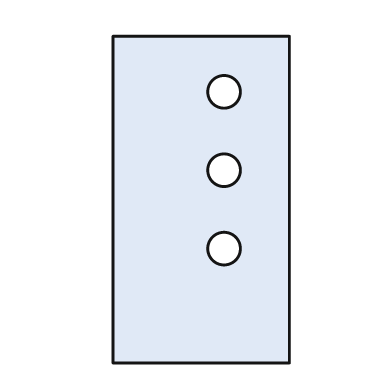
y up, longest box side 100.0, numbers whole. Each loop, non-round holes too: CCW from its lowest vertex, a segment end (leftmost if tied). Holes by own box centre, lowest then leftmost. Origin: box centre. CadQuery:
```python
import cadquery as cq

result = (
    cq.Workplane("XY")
    .moveTo(-27.0, -50.0)
    .lineTo(27.0, -50.0)
    .lineTo(27.0, 50.0)
    .lineTo(-27.0, 50.0)
    .close()
    .moveTo(7.0, -15.0)
    .circle(5.0)
    .moveTo(7.0, 9.0)
    .circle(5.0)
    .moveTo(7.0, 33.0)
    .circle(5.0)
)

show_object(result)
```